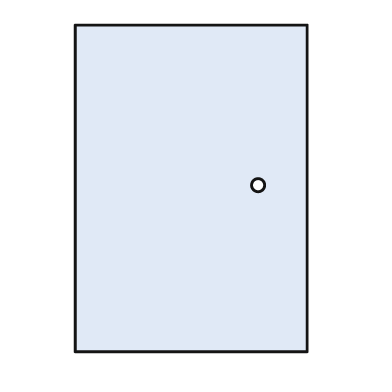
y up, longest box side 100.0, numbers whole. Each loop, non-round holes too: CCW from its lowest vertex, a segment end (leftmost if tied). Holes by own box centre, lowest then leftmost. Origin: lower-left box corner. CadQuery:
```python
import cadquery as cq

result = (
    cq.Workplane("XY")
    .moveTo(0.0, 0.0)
    .lineTo(71.0, 0.0)
    .lineTo(71.0, 100.0)
    .lineTo(0.0, 100.0)
    .close()
    .moveTo(56.0, 51.0)
    .circle(2.0)
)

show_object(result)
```